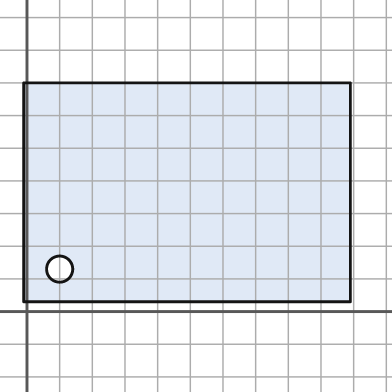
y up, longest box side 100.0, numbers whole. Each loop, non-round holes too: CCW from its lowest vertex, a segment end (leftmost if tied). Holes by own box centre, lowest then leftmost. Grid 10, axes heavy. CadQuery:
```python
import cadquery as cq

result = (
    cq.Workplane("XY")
    .moveTo(-1.0, 3.0)
    .lineTo(99.0, 3.0)
    .lineTo(99.0, 70.0)
    .lineTo(-1.0, 70.0)
    .close()
    .moveTo(10.0, 13.0)
    .circle(4.0)
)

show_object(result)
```